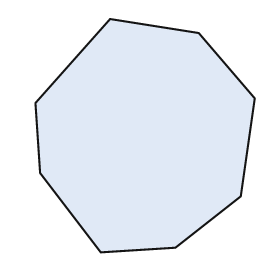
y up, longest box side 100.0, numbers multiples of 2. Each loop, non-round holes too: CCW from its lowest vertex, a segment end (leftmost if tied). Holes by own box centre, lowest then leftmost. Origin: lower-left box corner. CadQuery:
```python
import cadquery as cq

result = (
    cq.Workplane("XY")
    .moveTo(28.0, 0.0)
    .lineTo(60.0, 2.0)
    .lineTo(88.0, 24.0)
    .lineTo(94.0, 66.0)
    .lineTo(70.0, 94.0)
    .lineTo(32.0, 100.0)
    .lineTo(0.0, 64.0)
    .lineTo(2.0, 34.0)
    .close()
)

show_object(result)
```